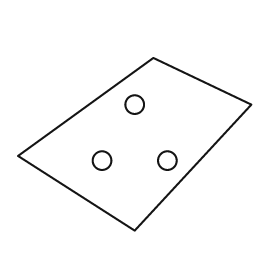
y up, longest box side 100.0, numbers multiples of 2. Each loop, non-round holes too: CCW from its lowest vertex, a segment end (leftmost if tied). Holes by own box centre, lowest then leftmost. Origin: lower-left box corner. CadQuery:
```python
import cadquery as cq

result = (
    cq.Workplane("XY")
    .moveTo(50.0, 0.0)
    .lineTo(100.0, 54.0)
    .lineTo(58.0, 74.0)
    .lineTo(0.0, 32.0)
    .close()
    .moveTo(36.0, 30.0)
    .circle(4.0)
    .moveTo(64.0, 30.0)
    .circle(4.0)
    .moveTo(50.0, 54.0)
    .circle(4.0)
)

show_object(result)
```